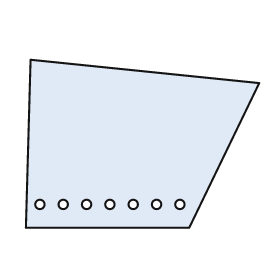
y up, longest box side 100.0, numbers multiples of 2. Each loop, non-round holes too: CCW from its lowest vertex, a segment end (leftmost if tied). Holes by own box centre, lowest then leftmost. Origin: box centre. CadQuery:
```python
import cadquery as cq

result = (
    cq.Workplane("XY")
    .moveTo(-50.0, -36.0)
    .lineTo(20.0, -36.0)
    .lineTo(50.0, 26.0)
    .lineTo(-48.0, 36.0)
    .close()
    .moveTo(-44.0, -26.0)
    .circle(2.0)
    .moveTo(-34.0, -26.0)
    .circle(2.0)
    .moveTo(-24.0, -26.0)
    .circle(2.0)
    .moveTo(-14.0, -26.0)
    .circle(2.0)
    .moveTo(-4.0, -26.0)
    .circle(2.0)
    .moveTo(6.0, -26.0)
    .circle(2.0)
    .moveTo(16.0, -26.0)
    .circle(2.0)
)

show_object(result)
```